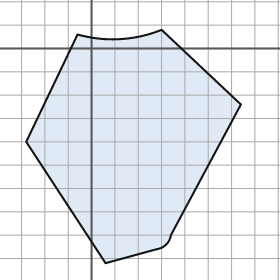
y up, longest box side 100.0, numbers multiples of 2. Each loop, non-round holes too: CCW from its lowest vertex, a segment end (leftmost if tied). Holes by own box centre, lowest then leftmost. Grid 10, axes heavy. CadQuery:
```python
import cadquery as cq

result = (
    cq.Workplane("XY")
    .moveTo(6.0, -92.0)
    .lineTo(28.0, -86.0)
    .threePointArc((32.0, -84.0), (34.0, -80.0))
    .lineTo(64.0, -24.0)
    .lineTo(30.0, 8.0)
    .threePointArc((12.0, 4.0), (-6.0, 6.0))
    .lineTo(-28.0, -40.0)
    .close()
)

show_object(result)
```